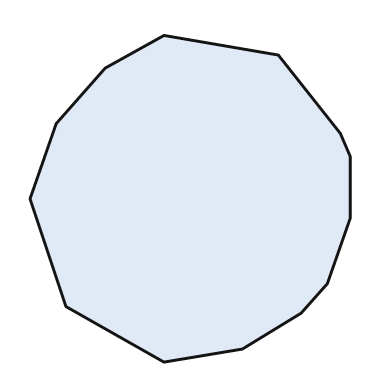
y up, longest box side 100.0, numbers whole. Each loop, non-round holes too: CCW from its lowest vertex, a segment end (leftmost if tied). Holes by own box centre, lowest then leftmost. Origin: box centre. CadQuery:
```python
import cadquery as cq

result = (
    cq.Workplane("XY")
    .moveTo(-8.0, -50.0)
    .lineTo(16.0, -46.0)
    .lineTo(34.0, -35.0)
    .lineTo(42.0, -26.0)
    .lineTo(49.0, -6.0)
    .lineTo(49.0, 13.0)
    .lineTo(46.0, 20.0)
    .lineTo(27.0, 44.0)
    .lineTo(-8.0, 50.0)
    .lineTo(-26.0, 40.0)
    .lineTo(-41.0, 23.0)
    .lineTo(-49.0, 0.0)
    .lineTo(-38.0, -33.0)
    .close()
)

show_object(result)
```